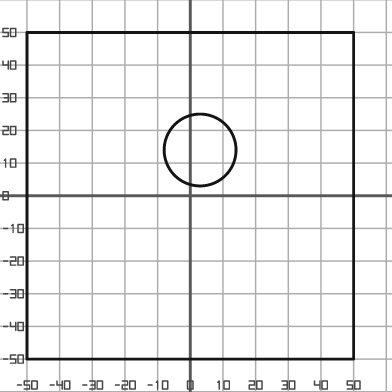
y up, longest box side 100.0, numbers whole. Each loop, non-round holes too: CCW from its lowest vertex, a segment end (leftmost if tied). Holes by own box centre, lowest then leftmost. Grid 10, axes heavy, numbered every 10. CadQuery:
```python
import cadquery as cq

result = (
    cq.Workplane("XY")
    .moveTo(-50.0, -50.0)
    .lineTo(50.0, -50.0)
    .lineTo(50.0, 50.0)
    .lineTo(-50.0, 50.0)
    .close()
    .moveTo(3.0, 14.0)
    .circle(11.0)
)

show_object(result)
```